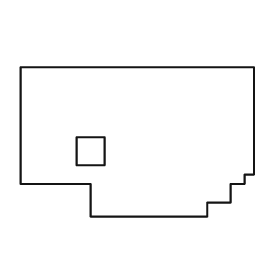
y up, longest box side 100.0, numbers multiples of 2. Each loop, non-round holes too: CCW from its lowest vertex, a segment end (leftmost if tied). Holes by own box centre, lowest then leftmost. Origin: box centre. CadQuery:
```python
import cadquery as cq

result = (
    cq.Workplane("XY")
    .moveTo(-20.0, -32.0)
    .lineTo(30.0, -32.0)
    .lineTo(30.0, -26.0)
    .lineTo(40.0, -26.0)
    .lineTo(40.0, -18.0)
    .lineTo(46.0, -18.0)
    .lineTo(46.0, -14.0)
    .lineTo(50.0, -14.0)
    .lineTo(50.0, 32.0)
    .lineTo(-50.0, 32.0)
    .lineTo(-50.0, -18.0)
    .lineTo(-20.0, -18.0)
    .close()
    .moveTo(-26.0, -10.0)
    .lineTo(-14.0, -10.0)
    .lineTo(-14.0, 2.0)
    .lineTo(-26.0, 2.0)
    .close()
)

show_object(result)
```